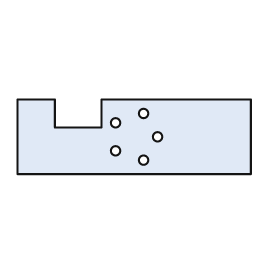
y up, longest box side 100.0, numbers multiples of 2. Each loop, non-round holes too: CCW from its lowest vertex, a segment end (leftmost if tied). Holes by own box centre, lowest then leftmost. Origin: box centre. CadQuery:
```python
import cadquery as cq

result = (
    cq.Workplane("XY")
    .moveTo(-50.0, -16.0)
    .lineTo(50.0, -16.0)
    .lineTo(50.0, 16.0)
    .lineTo(-14.0, 16.0)
    .lineTo(-14.0, 4.0)
    .lineTo(-34.0, 4.0)
    .lineTo(-34.0, 16.0)
    .lineTo(-50.0, 16.0)
    .close()
    .moveTo(4.0, -10.0)
    .circle(2.0)
    .moveTo(-8.0, -6.0)
    .circle(2.0)
    .moveTo(10.0, 0.0)
    .circle(2.0)
    .moveTo(-8.0, 6.0)
    .circle(2.0)
    .moveTo(4.0, 10.0)
    .circle(2.0)
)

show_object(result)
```